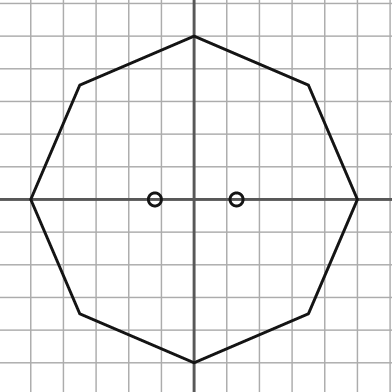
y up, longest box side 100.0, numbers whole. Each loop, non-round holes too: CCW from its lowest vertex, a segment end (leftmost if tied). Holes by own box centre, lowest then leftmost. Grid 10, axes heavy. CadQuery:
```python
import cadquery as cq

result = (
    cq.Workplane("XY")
    .moveTo(0.0, -50.0)
    .lineTo(35.0, -35.0)
    .lineTo(50.0, 0.0)
    .lineTo(35.0, 35.0)
    .lineTo(0.0, 50.0)
    .lineTo(-35.0, 35.0)
    .lineTo(-50.0, 0.0)
    .lineTo(-35.0, -35.0)
    .close()
    .moveTo(-12.0, 0.0)
    .circle(2.0)
    .moveTo(13.0, 0.0)
    .circle(2.0)
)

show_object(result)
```